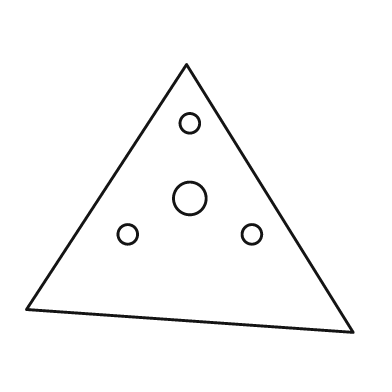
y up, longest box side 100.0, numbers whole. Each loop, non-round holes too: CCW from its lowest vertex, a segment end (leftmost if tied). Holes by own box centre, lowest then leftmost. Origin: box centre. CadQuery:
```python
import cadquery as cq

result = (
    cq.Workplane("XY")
    .moveTo(50.0, -41.0)
    .lineTo(-1.0, 41.0)
    .lineTo(-50.0, -34.0)
    .close()
    .moveTo(-19.0, -11.0)
    .circle(3.0)
    .moveTo(19.0, -11.0)
    .circle(3.0)
    .moveTo(0.0, 0.0)
    .circle(5.0)
    .moveTo(0.0, 23.0)
    .circle(3.0)
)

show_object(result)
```